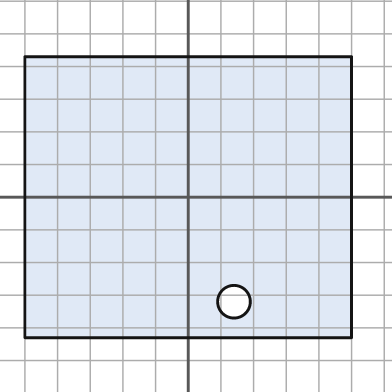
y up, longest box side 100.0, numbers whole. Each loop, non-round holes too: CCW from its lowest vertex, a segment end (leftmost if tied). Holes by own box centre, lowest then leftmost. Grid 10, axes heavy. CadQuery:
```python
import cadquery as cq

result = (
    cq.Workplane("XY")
    .moveTo(-50.0, -43.0)
    .lineTo(50.0, -43.0)
    .lineTo(50.0, 43.0)
    .lineTo(-50.0, 43.0)
    .close()
    .moveTo(14.0, -32.0)
    .circle(5.0)
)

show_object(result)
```